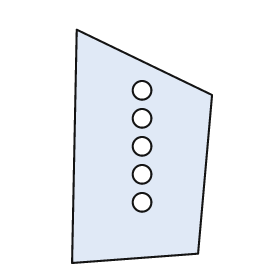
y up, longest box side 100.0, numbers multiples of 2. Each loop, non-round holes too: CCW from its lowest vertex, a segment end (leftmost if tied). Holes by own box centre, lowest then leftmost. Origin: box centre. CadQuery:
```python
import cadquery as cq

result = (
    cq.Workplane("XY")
    .moveTo(-30.0, -50.0)
    .lineTo(24.0, -46.0)
    .lineTo(30.0, 22.0)
    .lineTo(-28.0, 50.0)
    .close()
    .moveTo(0.0, -24.0)
    .circle(4.0)
    .moveTo(0.0, -12.0)
    .circle(4.0)
    .moveTo(0.0, 0.0)
    .circle(4.0)
    .moveTo(0.0, 12.0)
    .circle(4.0)
    .moveTo(0.0, 24.0)
    .circle(4.0)
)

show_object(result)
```